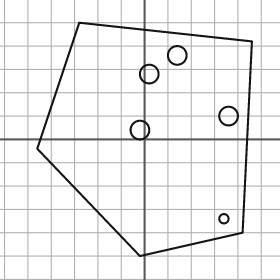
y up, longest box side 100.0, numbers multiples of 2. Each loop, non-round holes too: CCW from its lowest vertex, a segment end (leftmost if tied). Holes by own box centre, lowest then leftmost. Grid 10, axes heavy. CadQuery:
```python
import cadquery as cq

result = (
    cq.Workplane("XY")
    .moveTo(-2.0, -50.0)
    .lineTo(42.0, -40.0)
    .lineTo(46.0, 42.0)
    .lineTo(-28.0, 50.0)
    .lineTo(-46.0, -4.0)
    .close()
    .moveTo(34.0, -34.0)
    .circle(2.0)
    .moveTo(-2.0, 4.0)
    .circle(4.0)
    .moveTo(36.0, 10.0)
    .circle(4.0)
    .moveTo(2.0, 28.0)
    .circle(4.0)
    .moveTo(14.0, 36.0)
    .circle(4.0)
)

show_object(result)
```